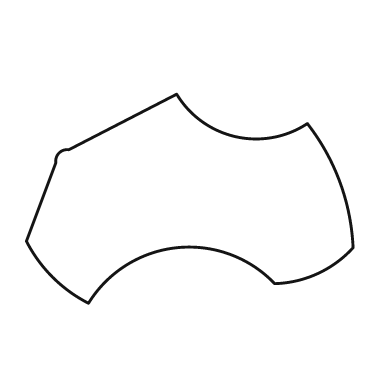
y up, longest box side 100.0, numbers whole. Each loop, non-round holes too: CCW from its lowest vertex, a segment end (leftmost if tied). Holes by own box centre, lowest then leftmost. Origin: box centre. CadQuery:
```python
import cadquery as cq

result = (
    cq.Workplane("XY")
    .moveTo(-31.0, -32.0)
    .threePointArc((-4.0, -15.0), (26.0, -26.0))
    .threePointArc((39.0, -23.0), (50.0, -15.0))
    .threePointArc((46.0, 5.0), (36.0, 23.0))
    .threePointArc((14.0, 19.0), (-4.0, 32.0))
    .lineTo(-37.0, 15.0)
    .threePointArc((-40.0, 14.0), (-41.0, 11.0))
    .lineTo(-50.0, -13.0)
    .threePointArc((-42.0, -24.0), (-31.0, -32.0))
    .close()
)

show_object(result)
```